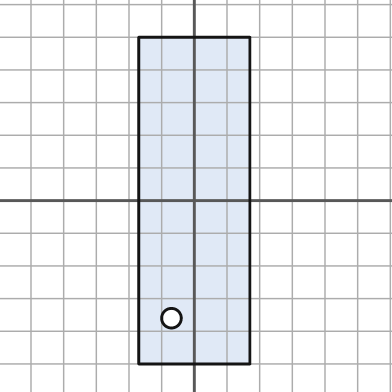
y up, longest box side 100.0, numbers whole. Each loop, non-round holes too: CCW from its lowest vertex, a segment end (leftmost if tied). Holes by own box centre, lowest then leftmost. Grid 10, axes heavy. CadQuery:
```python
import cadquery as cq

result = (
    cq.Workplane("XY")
    .moveTo(-17.0, -50.0)
    .lineTo(17.0, -50.0)
    .lineTo(17.0, 50.0)
    .lineTo(-17.0, 50.0)
    .close()
    .moveTo(-7.0, -36.0)
    .circle(3.0)
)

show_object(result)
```